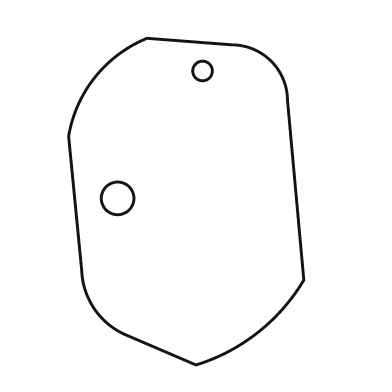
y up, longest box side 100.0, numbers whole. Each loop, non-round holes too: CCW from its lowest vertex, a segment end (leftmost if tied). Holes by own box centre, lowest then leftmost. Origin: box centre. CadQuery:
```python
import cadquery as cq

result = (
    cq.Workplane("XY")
    .moveTo(3.0, -50.0)
    .threePointArc((22.0, -40.0), (36.0, -24.0))
    .lineTo(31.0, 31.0)
    .threePointArc((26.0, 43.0), (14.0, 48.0))
    .lineTo(-12.0, 50.0)
    .threePointArc((-28.0, 38.0), (-36.0, 20.0))
    .lineTo(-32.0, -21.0)
    .threePointArc((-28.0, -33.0), (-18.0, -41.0))
    .close()
    .moveTo(-21.0, 1.0)
    .circle(5.0)
    .moveTo(5.0, 40.0)
    .circle(3.0)
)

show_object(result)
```